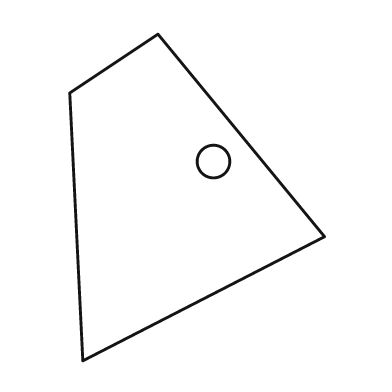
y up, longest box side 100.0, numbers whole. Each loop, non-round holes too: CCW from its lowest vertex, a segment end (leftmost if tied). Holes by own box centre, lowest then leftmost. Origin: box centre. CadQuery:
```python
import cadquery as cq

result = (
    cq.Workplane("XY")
    .moveTo(-35.0, -50.0)
    .lineTo(39.0, -12.0)
    .lineTo(-12.0, 50.0)
    .lineTo(-39.0, 32.0)
    .close()
    .moveTo(5.0, 11.0)
    .circle(5.0)
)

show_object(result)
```